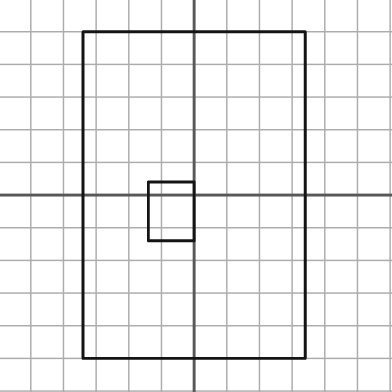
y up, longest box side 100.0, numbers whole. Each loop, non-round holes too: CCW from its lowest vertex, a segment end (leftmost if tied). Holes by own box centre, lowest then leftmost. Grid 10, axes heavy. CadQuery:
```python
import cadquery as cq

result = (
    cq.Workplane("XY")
    .moveTo(-34.0, -50.0)
    .lineTo(34.0, -50.0)
    .lineTo(34.0, 50.0)
    .lineTo(-34.0, 50.0)
    .close()
    .moveTo(-14.0, -14.0)
    .lineTo(0.0, -14.0)
    .lineTo(0.0, 4.0)
    .lineTo(-14.0, 4.0)
    .close()
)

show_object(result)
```